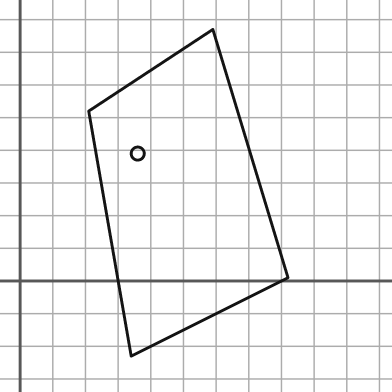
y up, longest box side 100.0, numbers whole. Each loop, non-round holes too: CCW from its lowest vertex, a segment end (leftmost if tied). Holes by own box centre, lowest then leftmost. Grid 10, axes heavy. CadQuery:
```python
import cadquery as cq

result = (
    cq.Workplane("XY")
    .moveTo(34.0, -23.0)
    .lineTo(82.0, 1.0)
    .lineTo(59.0, 77.0)
    .lineTo(21.0, 52.0)
    .close()
    .moveTo(36.0, 39.0)
    .circle(2.0)
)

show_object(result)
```